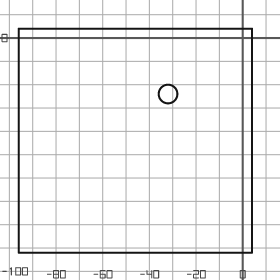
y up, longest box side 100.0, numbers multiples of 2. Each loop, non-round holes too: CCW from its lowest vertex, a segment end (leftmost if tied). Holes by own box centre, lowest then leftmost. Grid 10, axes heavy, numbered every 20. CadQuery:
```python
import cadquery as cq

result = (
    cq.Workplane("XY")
    .moveTo(-96.0, -92.0)
    .lineTo(4.0, -92.0)
    .lineTo(4.0, 4.0)
    .lineTo(-96.0, 4.0)
    .close()
    .moveTo(-32.0, -24.0)
    .circle(4.0)
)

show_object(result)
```